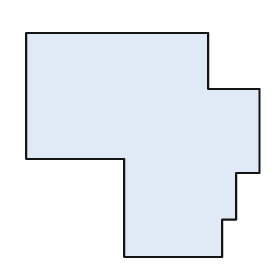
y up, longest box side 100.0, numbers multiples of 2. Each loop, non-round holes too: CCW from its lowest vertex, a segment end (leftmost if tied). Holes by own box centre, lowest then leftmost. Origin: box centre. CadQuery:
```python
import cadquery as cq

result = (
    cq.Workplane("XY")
    .moveTo(-8.0, -48.0)
    .lineTo(34.0, -48.0)
    .lineTo(34.0, -32.0)
    .lineTo(40.0, -32.0)
    .lineTo(40.0, -12.0)
    .lineTo(50.0, -12.0)
    .lineTo(50.0, 24.0)
    .lineTo(28.0, 24.0)
    .lineTo(28.0, 48.0)
    .lineTo(-50.0, 48.0)
    .lineTo(-50.0, -6.0)
    .lineTo(-8.0, -6.0)
    .close()
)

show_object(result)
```